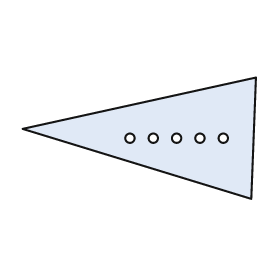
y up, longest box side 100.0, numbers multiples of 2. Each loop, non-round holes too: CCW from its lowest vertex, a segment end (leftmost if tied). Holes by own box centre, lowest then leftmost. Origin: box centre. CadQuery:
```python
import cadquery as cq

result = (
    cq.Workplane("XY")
    .moveTo(48.0, -26.0)
    .lineTo(50.0, 26.0)
    .lineTo(-50.0, 4.0)
    .close()
    .moveTo(-4.0, 0.0)
    .circle(2.0)
    .moveTo(6.0, 0.0)
    .circle(2.0)
    .moveTo(16.0, 0.0)
    .circle(2.0)
    .moveTo(26.0, 0.0)
    .circle(2.0)
    .moveTo(36.0, 0.0)
    .circle(2.0)
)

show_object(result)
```